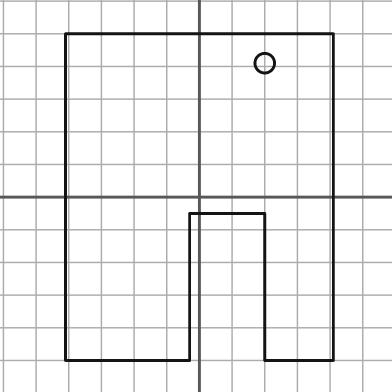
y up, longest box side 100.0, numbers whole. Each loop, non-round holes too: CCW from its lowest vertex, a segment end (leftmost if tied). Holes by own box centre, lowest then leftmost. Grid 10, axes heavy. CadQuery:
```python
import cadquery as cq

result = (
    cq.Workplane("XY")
    .moveTo(-41.0, -50.0)
    .lineTo(-3.0, -50.0)
    .lineTo(-3.0, -5.0)
    .lineTo(20.0, -5.0)
    .lineTo(20.0, -50.0)
    .lineTo(41.0, -50.0)
    .lineTo(41.0, 50.0)
    .lineTo(-41.0, 50.0)
    .close()
    .moveTo(20.0, 41.0)
    .circle(3.0)
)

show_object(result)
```